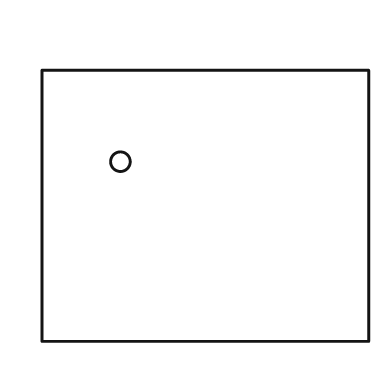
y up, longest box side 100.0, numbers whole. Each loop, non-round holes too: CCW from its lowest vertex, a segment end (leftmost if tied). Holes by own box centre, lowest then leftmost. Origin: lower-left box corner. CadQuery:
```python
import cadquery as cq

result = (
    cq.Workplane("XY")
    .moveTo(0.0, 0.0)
    .lineTo(100.0, 0.0)
    .lineTo(100.0, 83.0)
    .lineTo(0.0, 83.0)
    .close()
    .moveTo(24.0, 55.0)
    .circle(3.0)
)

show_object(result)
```